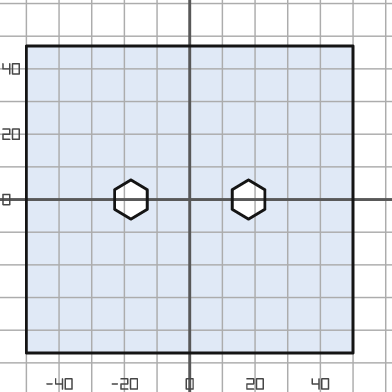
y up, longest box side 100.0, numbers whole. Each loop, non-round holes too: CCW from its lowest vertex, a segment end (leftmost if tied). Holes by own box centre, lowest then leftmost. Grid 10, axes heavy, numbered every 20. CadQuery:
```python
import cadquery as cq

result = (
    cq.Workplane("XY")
    .moveTo(-50.0, -47.0)
    .lineTo(50.0, -47.0)
    .lineTo(50.0, 47.0)
    .lineTo(-50.0, 47.0)
    .close()
    .moveTo(-18.0, -6.0)
    .lineTo(-13.0, -3.0)
    .lineTo(-13.0, 3.0)
    .lineTo(-18.0, 6.0)
    .lineTo(-23.0, 3.0)
    .lineTo(-23.0, -3.0)
    .close()
    .moveTo(18.0, -6.0)
    .lineTo(23.0, -3.0)
    .lineTo(23.0, 3.0)
    .lineTo(18.0, 6.0)
    .lineTo(13.0, 3.0)
    .lineTo(13.0, -3.0)
    .close()
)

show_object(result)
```